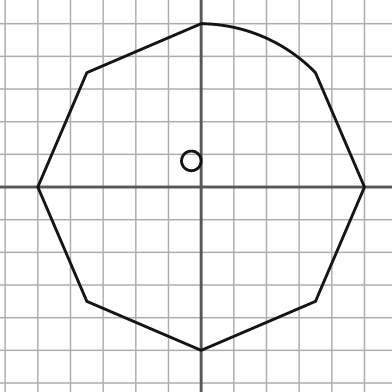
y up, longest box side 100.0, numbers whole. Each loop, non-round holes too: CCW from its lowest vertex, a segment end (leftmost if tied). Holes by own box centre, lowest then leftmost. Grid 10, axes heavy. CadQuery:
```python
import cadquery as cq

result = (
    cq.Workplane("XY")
    .moveTo(0.0, -50.0)
    .lineTo(35.0, -35.0)
    .lineTo(50.0, 0.0)
    .lineTo(35.0, 35.0)
    .threePointArc((19.0, 46.0), (0.0, 50.0))
    .lineTo(-35.0, 35.0)
    .lineTo(-50.0, 0.0)
    .lineTo(-35.0, -35.0)
    .close()
    .moveTo(-3.0, 8.0)
    .circle(3.0)
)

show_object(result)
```